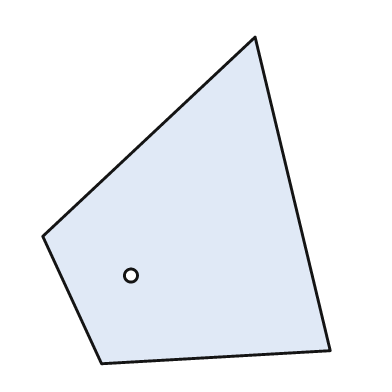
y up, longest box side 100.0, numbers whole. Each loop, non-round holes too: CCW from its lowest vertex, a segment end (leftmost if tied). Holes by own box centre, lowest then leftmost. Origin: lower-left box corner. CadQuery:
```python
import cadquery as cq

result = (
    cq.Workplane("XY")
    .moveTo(18.0, 0.0)
    .lineTo(88.0, 4.0)
    .lineTo(65.0, 100.0)
    .lineTo(0.0, 39.0)
    .close()
    .moveTo(27.0, 27.0)
    .circle(2.0)
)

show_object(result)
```